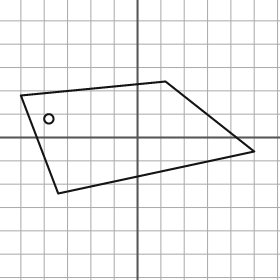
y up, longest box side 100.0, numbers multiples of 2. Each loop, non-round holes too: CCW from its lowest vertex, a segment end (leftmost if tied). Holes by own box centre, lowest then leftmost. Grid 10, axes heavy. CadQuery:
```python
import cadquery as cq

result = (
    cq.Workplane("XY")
    .moveTo(-34.0, -24.0)
    .lineTo(50.0, -6.0)
    .lineTo(12.0, 24.0)
    .lineTo(-50.0, 18.0)
    .close()
    .moveTo(-38.0, 8.0)
    .circle(2.0)
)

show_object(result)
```